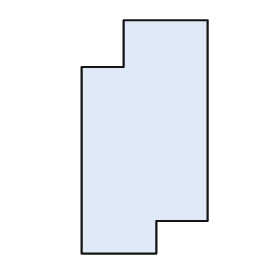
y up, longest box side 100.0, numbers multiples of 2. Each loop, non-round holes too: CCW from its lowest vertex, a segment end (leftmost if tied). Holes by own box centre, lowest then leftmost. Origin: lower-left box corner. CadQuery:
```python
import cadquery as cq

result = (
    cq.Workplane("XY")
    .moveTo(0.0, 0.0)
    .lineTo(32.0, 0.0)
    .lineTo(32.0, 14.0)
    .lineTo(54.0, 14.0)
    .lineTo(54.0, 100.0)
    .lineTo(18.0, 100.0)
    .lineTo(18.0, 80.0)
    .lineTo(0.0, 80.0)
    .close()
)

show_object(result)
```